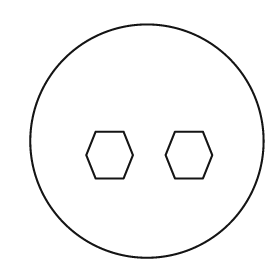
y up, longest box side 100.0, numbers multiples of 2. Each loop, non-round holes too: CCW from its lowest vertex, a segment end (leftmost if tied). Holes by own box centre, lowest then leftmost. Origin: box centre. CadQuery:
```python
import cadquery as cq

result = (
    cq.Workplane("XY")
    .moveTo(0.0, 0.0)
    .circle(50.0)
    .moveTo(-22.0, -16.0)
    .lineTo(-10.0, -16.0)
    .lineTo(-6.0, -6.0)
    .lineTo(-10.0, 4.0)
    .lineTo(-22.0, 4.0)
    .lineTo(-26.0, -6.0)
    .close()
    .moveTo(12.0, -16.0)
    .lineTo(24.0, -16.0)
    .lineTo(28.0, -6.0)
    .lineTo(24.0, 4.0)
    .lineTo(12.0, 4.0)
    .lineTo(8.0, -6.0)
    .close()
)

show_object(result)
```